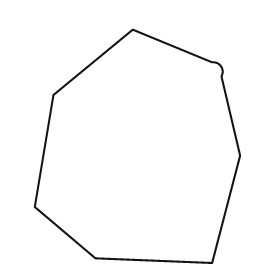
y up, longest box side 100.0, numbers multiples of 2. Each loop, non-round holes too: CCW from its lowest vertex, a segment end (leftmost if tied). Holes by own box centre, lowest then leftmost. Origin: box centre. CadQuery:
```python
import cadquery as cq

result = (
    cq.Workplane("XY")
    .moveTo(32.0, -50.0)
    .lineTo(44.0, -4.0)
    .lineTo(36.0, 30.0)
    .threePointArc((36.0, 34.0), (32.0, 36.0))
    .lineTo(-2.0, 50.0)
    .lineTo(-36.0, 22.0)
    .lineTo(-44.0, -26.0)
    .lineTo(-18.0, -48.0)
    .close()
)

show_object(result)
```